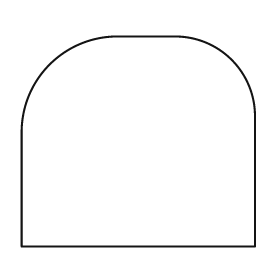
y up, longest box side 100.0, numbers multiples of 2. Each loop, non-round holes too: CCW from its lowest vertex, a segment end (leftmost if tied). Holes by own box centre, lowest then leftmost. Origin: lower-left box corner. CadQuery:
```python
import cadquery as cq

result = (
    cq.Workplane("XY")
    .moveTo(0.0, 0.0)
    .lineTo(100.0, 0.0)
    .lineTo(100.0, 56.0)
    .threePointArc((90.0, 80.0), (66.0, 90.0))
    .lineTo(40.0, 90.0)
    .threePointArc((12.0, 78.0), (0.0, 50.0))
    .close()
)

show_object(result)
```